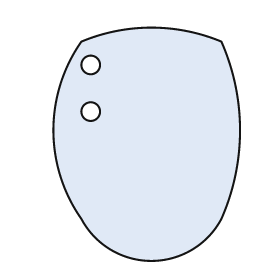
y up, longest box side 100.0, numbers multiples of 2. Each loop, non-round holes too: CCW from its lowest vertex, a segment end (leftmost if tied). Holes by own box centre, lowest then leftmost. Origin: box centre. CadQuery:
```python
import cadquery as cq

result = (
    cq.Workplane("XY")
    .moveTo(-28.0, -32.0)
    .threePointArc((2.0, -50.0), (32.0, -32.0))
    .threePointArc((40.0, 6.0), (32.0, 44.0))
    .threePointArc((2.0, 50.0), (-28.0, 44.0))
    .threePointArc((-40.0, 6.0), (-28.0, -32.0))
    .close()
    .moveTo(-24.0, 14.0)
    .circle(4.0)
    .moveTo(-24.0, 34.0)
    .circle(4.0)
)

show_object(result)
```